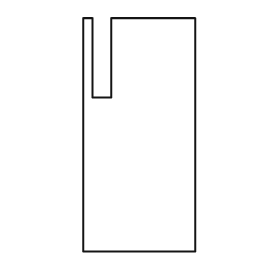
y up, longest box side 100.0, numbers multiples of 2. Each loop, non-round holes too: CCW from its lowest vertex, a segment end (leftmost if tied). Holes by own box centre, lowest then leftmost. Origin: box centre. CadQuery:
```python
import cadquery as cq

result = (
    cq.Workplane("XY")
    .moveTo(-24.0, -50.0)
    .lineTo(24.0, -50.0)
    .lineTo(24.0, 50.0)
    .lineTo(-12.0, 50.0)
    .lineTo(-12.0, 16.0)
    .lineTo(-20.0, 16.0)
    .lineTo(-20.0, 50.0)
    .lineTo(-24.0, 50.0)
    .close()
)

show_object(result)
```